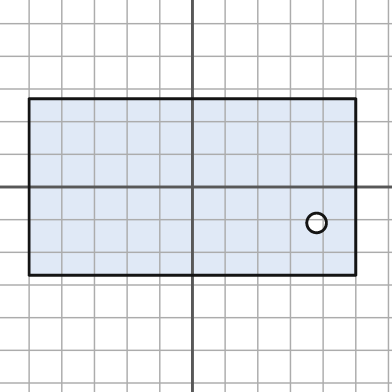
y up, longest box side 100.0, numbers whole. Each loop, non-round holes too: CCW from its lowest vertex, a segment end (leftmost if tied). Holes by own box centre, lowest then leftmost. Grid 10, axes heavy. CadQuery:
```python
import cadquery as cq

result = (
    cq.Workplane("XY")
    .moveTo(-50.0, -27.0)
    .lineTo(50.0, -27.0)
    .lineTo(50.0, 27.0)
    .lineTo(-50.0, 27.0)
    .close()
    .moveTo(38.0, -11.0)
    .circle(3.0)
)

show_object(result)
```